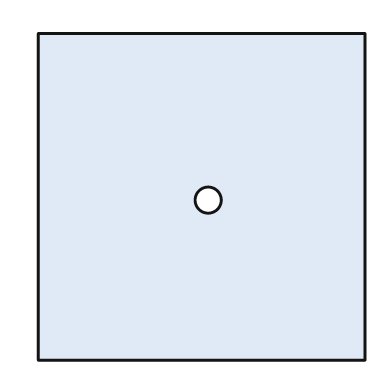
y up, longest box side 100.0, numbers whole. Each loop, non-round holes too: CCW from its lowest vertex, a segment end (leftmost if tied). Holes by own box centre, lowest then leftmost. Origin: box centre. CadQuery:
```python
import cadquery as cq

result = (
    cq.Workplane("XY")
    .moveTo(-50.0, -50.0)
    .lineTo(50.0, -50.0)
    .lineTo(50.0, 50.0)
    .lineTo(-50.0, 50.0)
    .close()
    .moveTo(2.0, -1.0)
    .circle(4.0)
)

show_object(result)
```